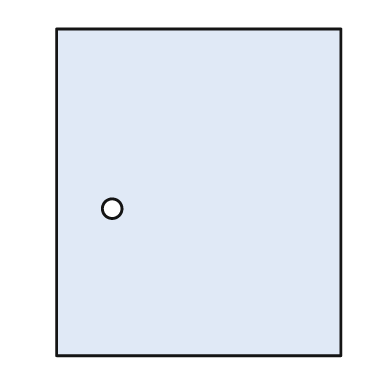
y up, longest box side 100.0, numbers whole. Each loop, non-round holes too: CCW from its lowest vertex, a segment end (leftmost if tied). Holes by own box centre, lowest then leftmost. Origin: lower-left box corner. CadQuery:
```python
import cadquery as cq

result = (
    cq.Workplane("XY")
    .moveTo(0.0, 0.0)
    .lineTo(87.0, 0.0)
    .lineTo(87.0, 100.0)
    .lineTo(0.0, 100.0)
    .close()
    .moveTo(17.0, 45.0)
    .circle(3.0)
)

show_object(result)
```